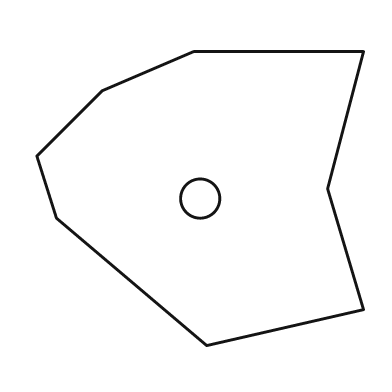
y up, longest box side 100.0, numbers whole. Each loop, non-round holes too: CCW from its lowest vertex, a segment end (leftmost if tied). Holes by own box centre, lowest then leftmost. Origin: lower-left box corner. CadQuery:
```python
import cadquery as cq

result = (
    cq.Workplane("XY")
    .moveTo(52.0, 0.0)
    .lineTo(100.0, 11.0)
    .lineTo(89.0, 48.0)
    .lineTo(100.0, 90.0)
    .lineTo(48.0, 90.0)
    .lineTo(20.0, 78.0)
    .lineTo(0.0, 58.0)
    .lineTo(6.0, 39.0)
    .close()
    .moveTo(50.0, 45.0)
    .circle(6.0)
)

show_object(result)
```